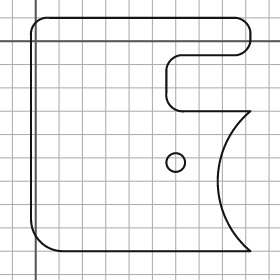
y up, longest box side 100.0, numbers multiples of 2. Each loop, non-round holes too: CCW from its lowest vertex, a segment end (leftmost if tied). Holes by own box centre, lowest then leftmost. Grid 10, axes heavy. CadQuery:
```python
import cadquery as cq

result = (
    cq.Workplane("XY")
    .moveTo(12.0, -90.0)
    .lineTo(92.0, -90.0)
    .threePointArc((78.0, -60.0), (92.0, -30.0))
    .lineTo(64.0, -30.0)
    .threePointArc((58.0, -28.0), (56.0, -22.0))
    .lineTo(56.0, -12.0)
    .threePointArc((58.0, -8.0), (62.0, -6.0))
    .lineTo(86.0, -6.0)
    .threePointArc((90.0, -4.0), (92.0, 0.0))
    .lineTo(92.0, 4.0)
    .threePointArc((90.0, 8.0), (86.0, 10.0))
    .lineTo(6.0, 10.0)
    .threePointArc((0.0, 8.0), (-2.0, 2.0))
    .lineTo(-2.0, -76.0)
    .threePointArc((2.0, -86.0), (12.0, -90.0))
    .close()
    .moveTo(60.0, -52.0)
    .circle(4.0)
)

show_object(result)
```